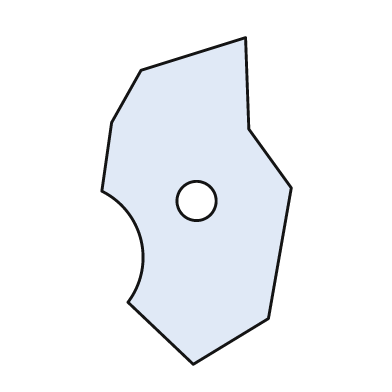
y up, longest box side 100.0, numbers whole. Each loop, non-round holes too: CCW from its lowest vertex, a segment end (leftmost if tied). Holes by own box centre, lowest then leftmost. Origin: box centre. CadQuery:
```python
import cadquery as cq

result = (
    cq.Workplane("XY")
    .moveTo(-1.0, -50.0)
    .lineTo(22.0, -36.0)
    .lineTo(29.0, 4.0)
    .lineTo(16.0, 22.0)
    .lineTo(15.0, 50.0)
    .lineTo(-17.0, 40.0)
    .lineTo(-26.0, 24.0)
    .lineTo(-29.0, 3.0)
    .threePointArc((-17.0, -12.0), (-21.0, -31.0))
    .close()
    .moveTo(0.0, 0.0)
    .circle(6.0)
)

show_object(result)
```